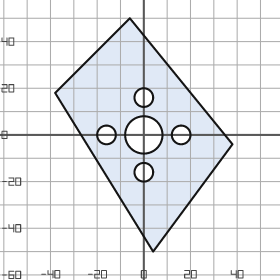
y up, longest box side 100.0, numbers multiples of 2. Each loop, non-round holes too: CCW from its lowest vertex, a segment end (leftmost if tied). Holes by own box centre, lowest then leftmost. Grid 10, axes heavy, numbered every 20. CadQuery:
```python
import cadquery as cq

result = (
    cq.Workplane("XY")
    .moveTo(4.0, -50.0)
    .lineTo(38.0, -4.0)
    .lineTo(-6.0, 50.0)
    .lineTo(-38.0, 18.0)
    .close()
    .moveTo(0.0, -16.0)
    .circle(4.0)
    .moveTo(-16.0, 0.0)
    .circle(4.0)
    .moveTo(0.0, 0.0)
    .circle(8.0)
    .moveTo(16.0, 0.0)
    .circle(4.0)
    .moveTo(0.0, 16.0)
    .circle(4.0)
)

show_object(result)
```